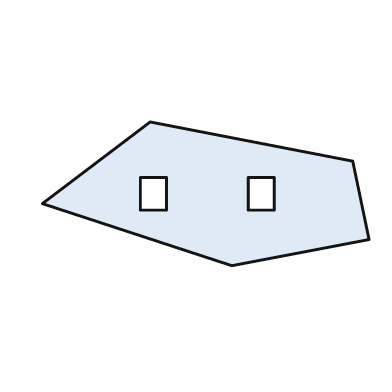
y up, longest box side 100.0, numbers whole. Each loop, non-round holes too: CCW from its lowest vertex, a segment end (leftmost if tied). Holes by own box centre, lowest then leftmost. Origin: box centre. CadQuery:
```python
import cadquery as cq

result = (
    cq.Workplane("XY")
    .moveTo(8.0, -22.0)
    .lineTo(50.0, -14.0)
    .lineTo(45.0, 10.0)
    .lineTo(-17.0, 22.0)
    .lineTo(-50.0, -3.0)
    .close()
    .moveTo(-20.0, -5.0)
    .lineTo(-12.0, -5.0)
    .lineTo(-12.0, 5.0)
    .lineTo(-20.0, 5.0)
    .close()
    .moveTo(13.0, -5.0)
    .lineTo(21.0, -5.0)
    .lineTo(21.0, 5.0)
    .lineTo(13.0, 5.0)
    .close()
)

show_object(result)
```